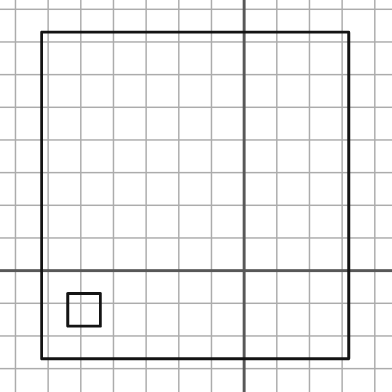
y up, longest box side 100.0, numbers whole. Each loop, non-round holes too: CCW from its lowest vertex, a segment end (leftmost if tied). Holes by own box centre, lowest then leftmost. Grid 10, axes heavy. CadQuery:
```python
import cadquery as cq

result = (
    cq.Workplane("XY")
    .moveTo(-62.0, -27.0)
    .lineTo(32.0, -27.0)
    .lineTo(32.0, 73.0)
    .lineTo(-62.0, 73.0)
    .close()
    .moveTo(-54.0, -17.0)
    .lineTo(-44.0, -17.0)
    .lineTo(-44.0, -7.0)
    .lineTo(-54.0, -7.0)
    .close()
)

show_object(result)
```